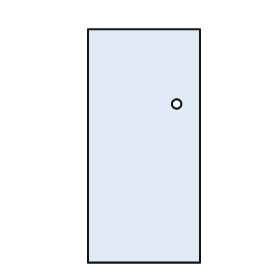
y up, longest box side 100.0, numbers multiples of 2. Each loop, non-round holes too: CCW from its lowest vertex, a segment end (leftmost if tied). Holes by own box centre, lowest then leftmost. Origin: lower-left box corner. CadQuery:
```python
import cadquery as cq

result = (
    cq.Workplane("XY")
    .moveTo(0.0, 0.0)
    .lineTo(48.0, 0.0)
    .lineTo(48.0, 100.0)
    .lineTo(0.0, 100.0)
    .close()
    .moveTo(38.0, 68.0)
    .circle(2.0)
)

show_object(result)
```